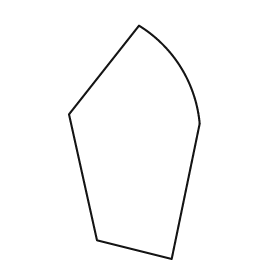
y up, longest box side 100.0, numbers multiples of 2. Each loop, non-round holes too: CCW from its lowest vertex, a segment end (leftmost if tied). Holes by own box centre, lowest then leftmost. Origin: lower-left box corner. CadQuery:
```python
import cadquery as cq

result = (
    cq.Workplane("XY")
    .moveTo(44.0, 0.0)
    .lineTo(56.0, 58.0)
    .threePointArc((48.0, 82.0), (30.0, 100.0))
    .lineTo(0.0, 62.0)
    .lineTo(12.0, 8.0)
    .close()
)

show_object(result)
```